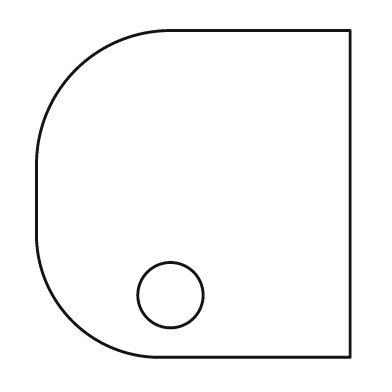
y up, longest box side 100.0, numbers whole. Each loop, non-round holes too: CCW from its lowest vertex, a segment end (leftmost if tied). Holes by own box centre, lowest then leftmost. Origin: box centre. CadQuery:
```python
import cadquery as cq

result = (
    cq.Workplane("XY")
    .moveTo(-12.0, -50.0)
    .lineTo(48.0, -50.0)
    .lineTo(48.0, 50.0)
    .lineTo(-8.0, 50.0)
    .threePointArc((-36.0, 38.0), (-48.0, 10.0))
    .lineTo(-48.0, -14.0)
    .threePointArc((-37.0, -39.0), (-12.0, -50.0))
    .close()
    .moveTo(-7.0, -31.0)
    .circle(10.0)
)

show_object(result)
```